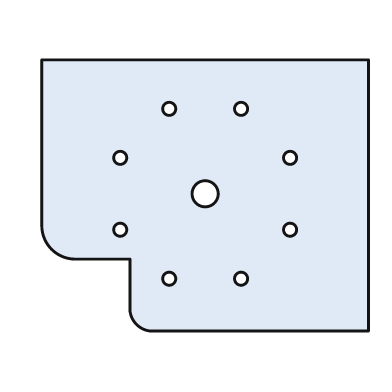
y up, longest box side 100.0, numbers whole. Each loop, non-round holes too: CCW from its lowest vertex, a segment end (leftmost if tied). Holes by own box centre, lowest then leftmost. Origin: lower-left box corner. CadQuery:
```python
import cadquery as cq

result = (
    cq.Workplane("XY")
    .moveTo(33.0, 0.0)
    .lineTo(100.0, 0.0)
    .lineTo(100.0, 83.0)
    .lineTo(0.0, 83.0)
    .lineTo(0.0, 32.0)
    .threePointArc((3.0, 25.0), (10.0, 22.0))
    .lineTo(27.0, 22.0)
    .lineTo(27.0, 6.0)
    .threePointArc((29.0, 2.0), (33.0, 0.0))
    .close()
    .moveTo(39.0, 16.0)
    .circle(2.0)
    .moveTo(61.0, 16.0)
    .circle(2.0)
    .moveTo(24.0, 31.0)
    .circle(2.0)
    .moveTo(76.0, 31.0)
    .circle(2.0)
    .moveTo(50.0, 42.0)
    .circle(4.0)
    .moveTo(24.0, 53.0)
    .circle(2.0)
    .moveTo(76.0, 53.0)
    .circle(2.0)
    .moveTo(39.0, 68.0)
    .circle(2.0)
    .moveTo(61.0, 68.0)
    .circle(2.0)
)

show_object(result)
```